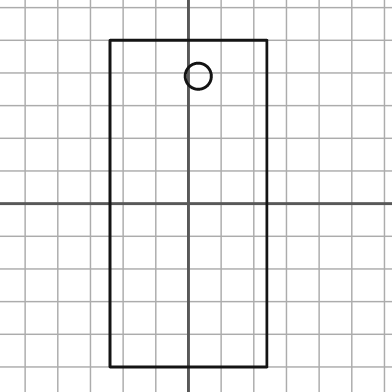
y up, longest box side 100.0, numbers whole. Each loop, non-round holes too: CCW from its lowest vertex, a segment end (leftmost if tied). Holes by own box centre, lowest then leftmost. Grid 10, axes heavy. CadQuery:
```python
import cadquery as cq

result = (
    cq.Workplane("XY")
    .moveTo(-24.0, -50.0)
    .lineTo(24.0, -50.0)
    .lineTo(24.0, 50.0)
    .lineTo(-24.0, 50.0)
    .close()
    .moveTo(3.0, 39.0)
    .circle(4.0)
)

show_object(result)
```